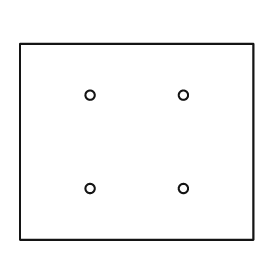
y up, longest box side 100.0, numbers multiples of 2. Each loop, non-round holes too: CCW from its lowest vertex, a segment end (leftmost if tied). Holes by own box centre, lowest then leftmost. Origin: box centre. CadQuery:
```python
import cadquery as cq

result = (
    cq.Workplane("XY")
    .moveTo(-50.0, -42.0)
    .lineTo(50.0, -42.0)
    .lineTo(50.0, 42.0)
    .lineTo(-50.0, 42.0)
    .close()
    .moveTo(-20.0, -20.0)
    .circle(2.0)
    .moveTo(20.0, -20.0)
    .circle(2.0)
    .moveTo(-20.0, 20.0)
    .circle(2.0)
    .moveTo(20.0, 20.0)
    .circle(2.0)
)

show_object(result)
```